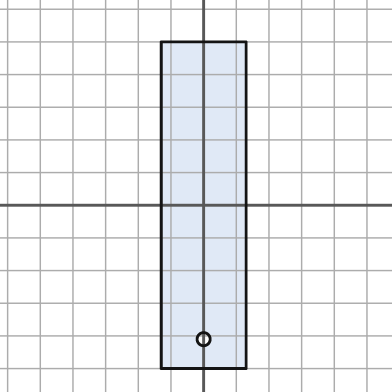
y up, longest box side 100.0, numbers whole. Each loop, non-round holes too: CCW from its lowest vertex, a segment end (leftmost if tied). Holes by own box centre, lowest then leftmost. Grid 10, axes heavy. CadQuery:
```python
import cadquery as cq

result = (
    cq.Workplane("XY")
    .moveTo(-13.0, -50.0)
    .lineTo(13.0, -50.0)
    .lineTo(13.0, 50.0)
    .lineTo(-13.0, 50.0)
    .close()
    .moveTo(0.0, -41.0)
    .circle(2.0)
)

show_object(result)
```